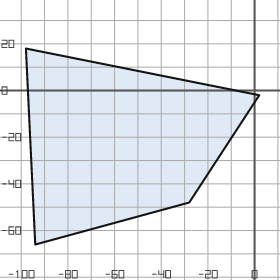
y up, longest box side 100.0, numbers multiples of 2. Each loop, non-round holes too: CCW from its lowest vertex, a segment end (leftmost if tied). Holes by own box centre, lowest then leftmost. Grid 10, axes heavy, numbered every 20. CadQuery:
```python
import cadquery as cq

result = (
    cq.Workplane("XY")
    .moveTo(-94.0, -66.0)
    .lineTo(-28.0, -48.0)
    .lineTo(2.0, -2.0)
    .lineTo(-98.0, 18.0)
    .close()
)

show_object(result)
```